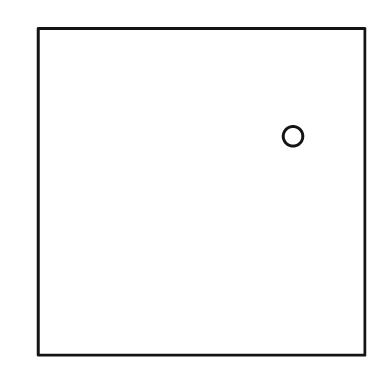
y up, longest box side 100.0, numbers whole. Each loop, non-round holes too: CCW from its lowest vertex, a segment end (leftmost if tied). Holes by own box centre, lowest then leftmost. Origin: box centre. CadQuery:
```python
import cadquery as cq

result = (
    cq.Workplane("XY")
    .moveTo(-50.0, -50.0)
    .lineTo(50.0, -50.0)
    .lineTo(50.0, 50.0)
    .lineTo(-50.0, 50.0)
    .close()
    .moveTo(28.0, 17.0)
    .circle(3.0)
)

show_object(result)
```